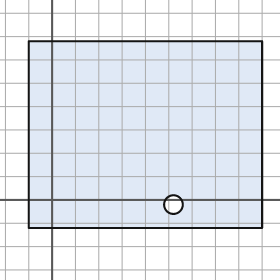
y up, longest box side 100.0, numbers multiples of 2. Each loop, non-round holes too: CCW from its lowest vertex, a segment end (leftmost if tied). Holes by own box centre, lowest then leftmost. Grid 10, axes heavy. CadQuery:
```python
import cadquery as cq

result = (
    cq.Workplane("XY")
    .moveTo(-10.0, -12.0)
    .lineTo(90.0, -12.0)
    .lineTo(90.0, 68.0)
    .lineTo(-10.0, 68.0)
    .close()
    .moveTo(52.0, -2.0)
    .circle(4.0)
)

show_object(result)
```